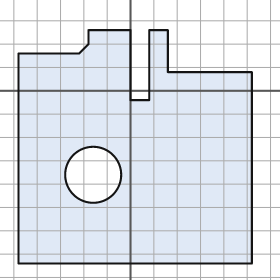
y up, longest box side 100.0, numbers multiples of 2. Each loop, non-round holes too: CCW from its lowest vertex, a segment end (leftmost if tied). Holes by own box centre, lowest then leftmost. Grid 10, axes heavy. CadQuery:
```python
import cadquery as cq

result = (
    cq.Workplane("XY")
    .moveTo(-48.0, -74.0)
    .lineTo(52.0, -74.0)
    .lineTo(52.0, 8.0)
    .lineTo(16.0, 8.0)
    .lineTo(16.0, 26.0)
    .lineTo(8.0, 26.0)
    .lineTo(8.0, -4.0)
    .lineTo(0.0, -4.0)
    .lineTo(0.0, 26.0)
    .lineTo(-18.0, 26.0)
    .lineTo(-18.0, 20.0)
    .lineTo(-22.0, 16.0)
    .lineTo(-48.0, 16.0)
    .close()
    .moveTo(-16.0, -36.0)
    .circle(12.0)
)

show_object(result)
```